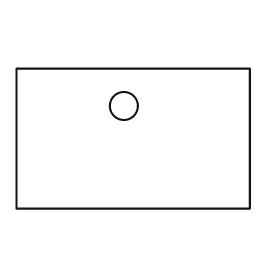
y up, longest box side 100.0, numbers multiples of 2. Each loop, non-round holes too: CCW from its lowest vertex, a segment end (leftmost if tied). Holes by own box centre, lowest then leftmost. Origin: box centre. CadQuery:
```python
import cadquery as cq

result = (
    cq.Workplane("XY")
    .moveTo(-50.0, -30.0)
    .lineTo(50.0, -30.0)
    .lineTo(50.0, 30.0)
    .lineTo(-50.0, 30.0)
    .close()
    .moveTo(-4.0, 14.0)
    .circle(6.0)
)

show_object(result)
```